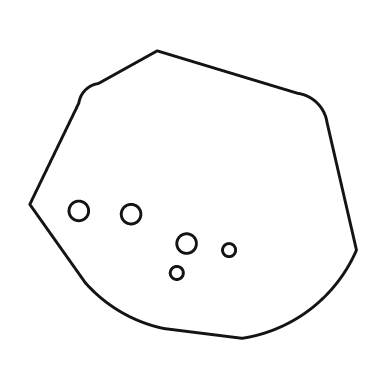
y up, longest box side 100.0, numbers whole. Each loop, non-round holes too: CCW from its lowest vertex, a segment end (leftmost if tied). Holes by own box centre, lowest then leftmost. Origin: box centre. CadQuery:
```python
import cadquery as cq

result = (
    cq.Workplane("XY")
    .moveTo(15.0, -44.0)
    .threePointArc((36.0, -35.0), (50.0, -17.0))
    .lineTo(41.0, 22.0)
    .threePointArc((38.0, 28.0), (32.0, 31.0))
    .lineTo(-11.0, 44.0)
    .lineTo(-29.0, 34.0)
    .threePointArc((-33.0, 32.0), (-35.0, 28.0))
    .lineTo(-50.0, -3.0)
    .lineTo(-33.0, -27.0)
    .threePointArc((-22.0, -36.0), (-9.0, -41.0))
    .close()
    .moveTo(-5.0, -24.0)
    .circle(2.0)
    .moveTo(11.0, -17.0)
    .circle(2.0)
    .moveTo(-2.0, -15.0)
    .circle(3.0)
    .moveTo(-19.0, -6.0)
    .circle(3.0)
    .moveTo(-35.0, -5.0)
    .circle(3.0)
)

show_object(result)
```